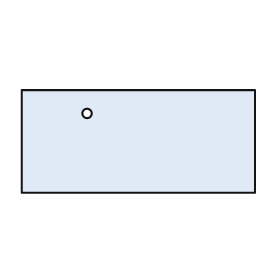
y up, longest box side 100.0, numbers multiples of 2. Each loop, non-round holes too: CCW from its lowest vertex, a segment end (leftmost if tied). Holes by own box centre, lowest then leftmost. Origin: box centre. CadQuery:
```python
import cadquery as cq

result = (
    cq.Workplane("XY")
    .moveTo(-50.0, -22.0)
    .lineTo(50.0, -22.0)
    .lineTo(50.0, 22.0)
    .lineTo(-50.0, 22.0)
    .close()
    .moveTo(-22.0, 12.0)
    .circle(2.0)
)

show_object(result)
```